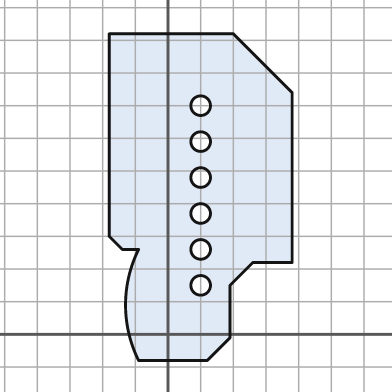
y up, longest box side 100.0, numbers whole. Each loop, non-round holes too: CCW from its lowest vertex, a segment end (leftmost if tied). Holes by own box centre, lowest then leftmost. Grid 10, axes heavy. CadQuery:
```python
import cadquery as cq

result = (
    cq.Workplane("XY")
    .moveTo(-9.0, -8.0)
    .lineTo(12.0, -8.0)
    .lineTo(19.0, -1.0)
    .lineTo(19.0, 15.0)
    .lineTo(26.0, 22.0)
    .lineTo(38.0, 22.0)
    .lineTo(38.0, 74.0)
    .lineTo(20.0, 92.0)
    .lineTo(-18.0, 92.0)
    .lineTo(-18.0, 30.0)
    .lineTo(-14.0, 26.0)
    .lineTo(-9.0, 26.0)
    .threePointArc((-13.0, 9.0), (-9.0, -8.0))
    .close()
    .moveTo(10.0, 15.0)
    .circle(3.0)
    .moveTo(10.0, 26.0)
    .circle(3.0)
    .moveTo(10.0, 37.0)
    .circle(3.0)
    .moveTo(10.0, 48.0)
    .circle(3.0)
    .moveTo(10.0, 59.0)
    .circle(3.0)
    .moveTo(10.0, 70.0)
    .circle(3.0)
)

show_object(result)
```